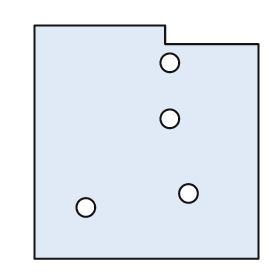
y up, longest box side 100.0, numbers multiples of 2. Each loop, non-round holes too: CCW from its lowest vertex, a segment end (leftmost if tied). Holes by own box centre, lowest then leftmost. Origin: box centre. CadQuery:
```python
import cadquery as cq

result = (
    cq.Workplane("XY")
    .moveTo(-48.0, -50.0)
    .lineTo(48.0, -50.0)
    .lineTo(48.0, 42.0)
    .lineTo(8.0, 42.0)
    .lineTo(8.0, 50.0)
    .lineTo(-48.0, 50.0)
    .close()
    .moveTo(-26.0, -28.0)
    .circle(4.0)
    .moveTo(18.0, -22.0)
    .circle(4.0)
    .moveTo(10.0, 10.0)
    .circle(4.0)
    .moveTo(10.0, 34.0)
    .circle(4.0)
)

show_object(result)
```